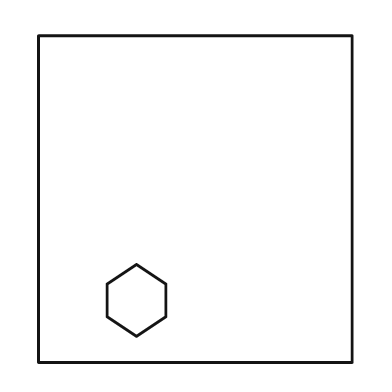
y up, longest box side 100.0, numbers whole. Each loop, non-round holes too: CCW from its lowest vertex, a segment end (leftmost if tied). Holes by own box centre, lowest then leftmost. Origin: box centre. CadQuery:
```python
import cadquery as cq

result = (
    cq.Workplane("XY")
    .moveTo(-48.0, -50.0)
    .lineTo(48.0, -50.0)
    .lineTo(48.0, 50.0)
    .lineTo(-48.0, 50.0)
    .close()
    .moveTo(-18.0, -42.0)
    .lineTo(-9.0, -36.0)
    .lineTo(-9.0, -26.0)
    .lineTo(-18.0, -20.0)
    .lineTo(-27.0, -26.0)
    .lineTo(-27.0, -36.0)
    .close()
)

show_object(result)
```